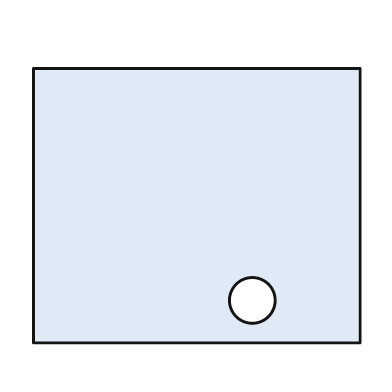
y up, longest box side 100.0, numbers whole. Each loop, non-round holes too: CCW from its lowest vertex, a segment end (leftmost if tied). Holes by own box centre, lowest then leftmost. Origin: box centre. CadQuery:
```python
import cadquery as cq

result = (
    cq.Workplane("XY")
    .moveTo(-50.0, -42.0)
    .lineTo(50.0, -42.0)
    .lineTo(50.0, 42.0)
    .lineTo(-50.0, 42.0)
    .close()
    .moveTo(17.0, -29.0)
    .circle(7.0)
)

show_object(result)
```